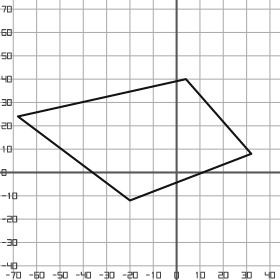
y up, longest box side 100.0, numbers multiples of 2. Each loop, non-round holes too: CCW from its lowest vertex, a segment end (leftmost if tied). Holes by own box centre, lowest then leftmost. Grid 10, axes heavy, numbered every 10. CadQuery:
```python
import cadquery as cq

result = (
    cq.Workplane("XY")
    .moveTo(-20.0, -12.0)
    .lineTo(32.0, 8.0)
    .lineTo(4.0, 40.0)
    .lineTo(-68.0, 24.0)
    .close()
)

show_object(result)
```